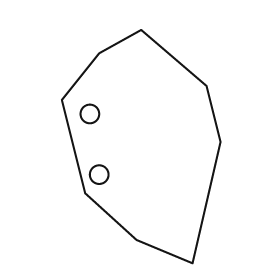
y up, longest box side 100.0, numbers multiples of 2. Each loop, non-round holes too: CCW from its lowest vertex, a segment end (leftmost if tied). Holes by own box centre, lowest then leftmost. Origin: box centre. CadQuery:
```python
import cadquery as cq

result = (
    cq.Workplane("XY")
    .moveTo(22.0, -50.0)
    .lineTo(34.0, 2.0)
    .lineTo(28.0, 26.0)
    .lineTo(0.0, 50.0)
    .lineTo(-18.0, 40.0)
    .lineTo(-34.0, 20.0)
    .lineTo(-24.0, -20.0)
    .lineTo(-2.0, -40.0)
    .close()
    .moveTo(-18.0, -12.0)
    .circle(4.0)
    .moveTo(-22.0, 14.0)
    .circle(4.0)
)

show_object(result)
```